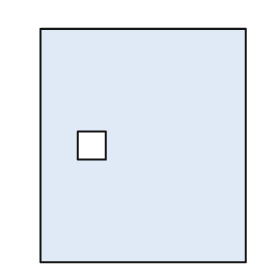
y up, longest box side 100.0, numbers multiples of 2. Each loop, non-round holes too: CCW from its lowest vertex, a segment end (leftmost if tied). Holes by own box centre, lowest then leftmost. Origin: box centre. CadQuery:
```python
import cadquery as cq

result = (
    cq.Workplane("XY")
    .moveTo(-44.0, -50.0)
    .lineTo(44.0, -50.0)
    .lineTo(44.0, 50.0)
    .lineTo(-44.0, 50.0)
    .close()
    .moveTo(-28.0, -6.0)
    .lineTo(-16.0, -6.0)
    .lineTo(-16.0, 6.0)
    .lineTo(-28.0, 6.0)
    .close()
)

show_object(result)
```